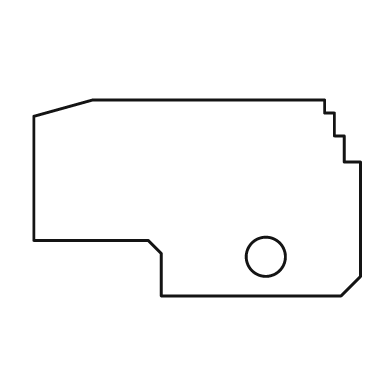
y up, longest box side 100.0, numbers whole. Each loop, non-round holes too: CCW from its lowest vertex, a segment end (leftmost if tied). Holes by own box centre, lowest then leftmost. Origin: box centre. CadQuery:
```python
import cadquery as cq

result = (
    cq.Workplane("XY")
    .moveTo(-11.0, -30.0)
    .lineTo(44.0, -30.0)
    .lineTo(50.0, -24.0)
    .lineTo(50.0, 11.0)
    .lineTo(45.0, 11.0)
    .lineTo(45.0, 19.0)
    .lineTo(42.0, 19.0)
    .lineTo(42.0, 26.0)
    .lineTo(39.0, 26.0)
    .lineTo(39.0, 30.0)
    .lineTo(-32.0, 30.0)
    .lineTo(-50.0, 25.0)
    .lineTo(-50.0, -13.0)
    .lineTo(-15.0, -13.0)
    .lineTo(-11.0, -17.0)
    .close()
    .moveTo(21.0, -18.0)
    .circle(6.0)
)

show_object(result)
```